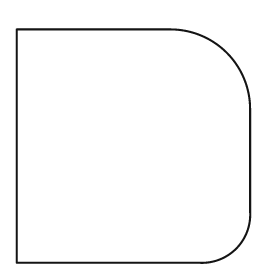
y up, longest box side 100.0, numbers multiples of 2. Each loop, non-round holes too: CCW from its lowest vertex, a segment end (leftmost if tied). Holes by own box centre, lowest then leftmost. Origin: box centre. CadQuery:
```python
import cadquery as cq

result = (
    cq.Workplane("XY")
    .moveTo(-50.0, -50.0)
    .lineTo(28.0, -50.0)
    .threePointArc((44.0, -44.0), (50.0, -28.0))
    .lineTo(50.0, 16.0)
    .threePointArc((40.0, 40.0), (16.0, 50.0))
    .lineTo(-50.0, 50.0)
    .close()
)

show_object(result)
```